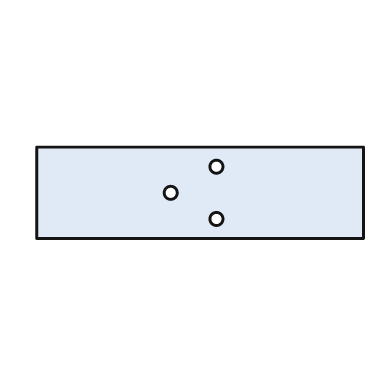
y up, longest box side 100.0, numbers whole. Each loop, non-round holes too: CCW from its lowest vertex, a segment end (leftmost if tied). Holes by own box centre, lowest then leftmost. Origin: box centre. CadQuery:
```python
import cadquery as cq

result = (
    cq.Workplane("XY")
    .moveTo(-50.0, -14.0)
    .lineTo(50.0, -14.0)
    .lineTo(50.0, 14.0)
    .lineTo(-50.0, 14.0)
    .close()
    .moveTo(5.0, -8.0)
    .circle(2.0)
    .moveTo(-9.0, 0.0)
    .circle(2.0)
    .moveTo(5.0, 8.0)
    .circle(2.0)
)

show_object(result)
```